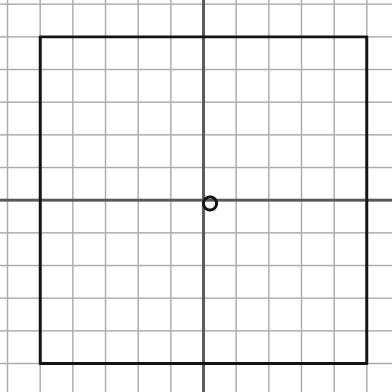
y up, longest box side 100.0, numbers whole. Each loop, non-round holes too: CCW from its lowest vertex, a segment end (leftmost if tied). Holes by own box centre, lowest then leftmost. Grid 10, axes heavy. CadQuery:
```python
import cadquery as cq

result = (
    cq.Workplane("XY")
    .moveTo(-50.0, -50.0)
    .lineTo(50.0, -50.0)
    .lineTo(50.0, 50.0)
    .lineTo(-50.0, 50.0)
    .close()
    .moveTo(2.0, -1.0)
    .circle(2.0)
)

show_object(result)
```